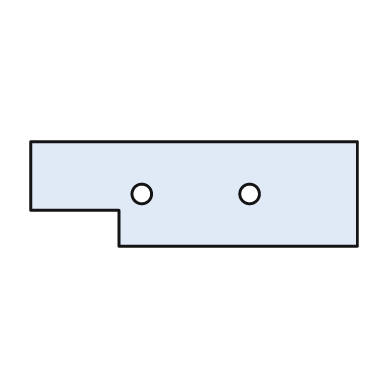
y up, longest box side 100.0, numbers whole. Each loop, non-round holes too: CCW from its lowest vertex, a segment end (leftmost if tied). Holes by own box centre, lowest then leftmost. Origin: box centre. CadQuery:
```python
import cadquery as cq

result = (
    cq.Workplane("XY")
    .moveTo(-23.0, -16.0)
    .lineTo(50.0, -16.0)
    .lineTo(50.0, 16.0)
    .lineTo(-50.0, 16.0)
    .lineTo(-50.0, -5.0)
    .lineTo(-23.0, -5.0)
    .close()
    .moveTo(-16.0, 0.0)
    .circle(3.0)
    .moveTo(17.0, 0.0)
    .circle(3.0)
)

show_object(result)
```